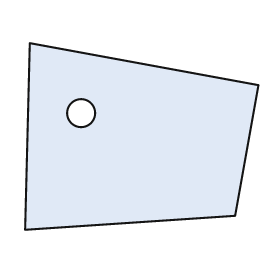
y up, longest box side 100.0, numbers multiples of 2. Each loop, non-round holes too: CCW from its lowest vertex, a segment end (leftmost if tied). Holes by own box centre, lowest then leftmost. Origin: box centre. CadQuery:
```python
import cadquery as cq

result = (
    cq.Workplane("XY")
    .moveTo(-50.0, -40.0)
    .lineTo(40.0, -34.0)
    .lineTo(50.0, 22.0)
    .lineTo(-48.0, 40.0)
    .close()
    .moveTo(-26.0, 10.0)
    .circle(6.0)
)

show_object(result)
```